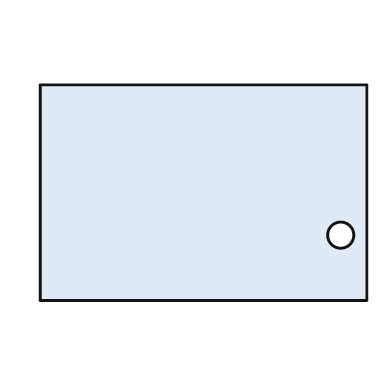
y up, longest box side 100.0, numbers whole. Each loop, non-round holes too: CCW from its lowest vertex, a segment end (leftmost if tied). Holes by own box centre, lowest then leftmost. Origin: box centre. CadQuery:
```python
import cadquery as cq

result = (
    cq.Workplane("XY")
    .moveTo(-50.0, -33.0)
    .lineTo(50.0, -33.0)
    .lineTo(50.0, 33.0)
    .lineTo(-50.0, 33.0)
    .close()
    .moveTo(42.0, -13.0)
    .circle(4.0)
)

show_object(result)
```